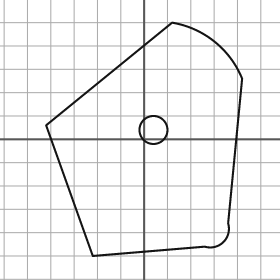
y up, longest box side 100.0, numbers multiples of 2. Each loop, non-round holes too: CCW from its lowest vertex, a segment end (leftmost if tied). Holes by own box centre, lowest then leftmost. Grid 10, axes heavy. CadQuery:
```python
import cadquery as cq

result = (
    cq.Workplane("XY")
    .moveTo(-22.0, -50.0)
    .lineTo(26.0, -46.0)
    .threePointArc((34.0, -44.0), (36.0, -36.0))
    .lineTo(42.0, 26.0)
    .threePointArc((30.0, 42.0), (12.0, 50.0))
    .lineTo(-42.0, 6.0)
    .close()
    .moveTo(4.0, 4.0)
    .circle(6.0)
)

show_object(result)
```